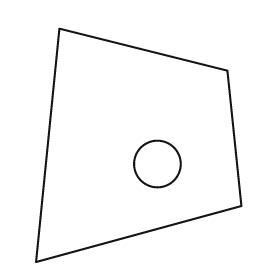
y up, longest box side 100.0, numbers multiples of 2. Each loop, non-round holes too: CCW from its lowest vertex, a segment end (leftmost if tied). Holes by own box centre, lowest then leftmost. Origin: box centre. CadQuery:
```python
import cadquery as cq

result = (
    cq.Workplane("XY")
    .moveTo(-44.0, -50.0)
    .lineTo(44.0, -26.0)
    .lineTo(38.0, 32.0)
    .lineTo(-34.0, 50.0)
    .close()
    .moveTo(8.0, -8.0)
    .circle(10.0)
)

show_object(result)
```